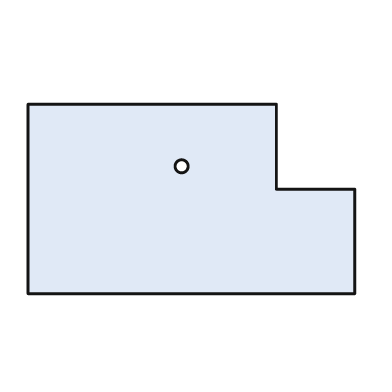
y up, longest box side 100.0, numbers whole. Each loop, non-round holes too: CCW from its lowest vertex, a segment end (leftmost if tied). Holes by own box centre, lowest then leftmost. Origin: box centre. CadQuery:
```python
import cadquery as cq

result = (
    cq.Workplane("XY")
    .moveTo(-50.0, -29.0)
    .lineTo(50.0, -29.0)
    .lineTo(50.0, 3.0)
    .lineTo(26.0, 3.0)
    .lineTo(26.0, 29.0)
    .lineTo(-50.0, 29.0)
    .close()
    .moveTo(-3.0, 10.0)
    .circle(2.0)
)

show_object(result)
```